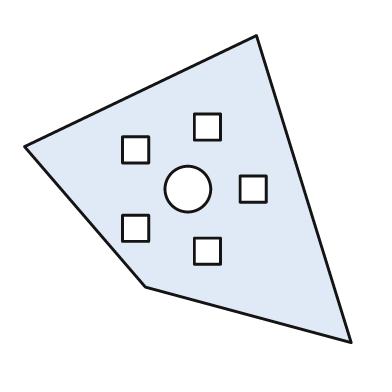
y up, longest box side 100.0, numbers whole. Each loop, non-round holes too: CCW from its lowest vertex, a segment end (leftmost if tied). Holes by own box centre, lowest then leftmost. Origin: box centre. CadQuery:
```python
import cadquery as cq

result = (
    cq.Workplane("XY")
    .moveTo(50.0, -47.0)
    .lineTo(21.0, 47.0)
    .lineTo(-50.0, 13.0)
    .lineTo(-13.0, -30.0)
    .close()
    .moveTo(2.0, -23.0)
    .lineTo(10.0, -23.0)
    .lineTo(10.0, -15.0)
    .lineTo(2.0, -15.0)
    .close()
    .moveTo(-20.0, -16.0)
    .lineTo(-12.0, -16.0)
    .lineTo(-12.0, -8.0)
    .lineTo(-20.0, -8.0)
    .close()
    .moveTo(0.0, 0.0)
    .circle(7.0)
    .moveTo(16.0, -4.0)
    .lineTo(24.0, -4.0)
    .lineTo(24.0, 4.0)
    .lineTo(16.0, 4.0)
    .close()
    .moveTo(-20.0, 8.0)
    .lineTo(-12.0, 8.0)
    .lineTo(-12.0, 16.0)
    .lineTo(-20.0, 16.0)
    .close()
    .moveTo(2.0, 15.0)
    .lineTo(10.0, 15.0)
    .lineTo(10.0, 23.0)
    .lineTo(2.0, 23.0)
    .close()
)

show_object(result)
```